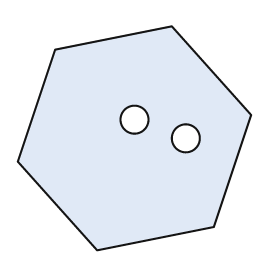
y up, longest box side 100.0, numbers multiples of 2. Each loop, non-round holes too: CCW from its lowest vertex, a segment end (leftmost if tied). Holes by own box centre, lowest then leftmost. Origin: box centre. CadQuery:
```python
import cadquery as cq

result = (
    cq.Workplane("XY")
    .moveTo(-16.0, -48.0)
    .lineTo(34.0, -38.0)
    .lineTo(50.0, 10.0)
    .lineTo(16.0, 48.0)
    .lineTo(-34.0, 38.0)
    .lineTo(-50.0, -10.0)
    .close()
    .moveTo(22.0, 0.0)
    .circle(6.0)
    .moveTo(0.0, 8.0)
    .circle(6.0)
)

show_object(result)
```